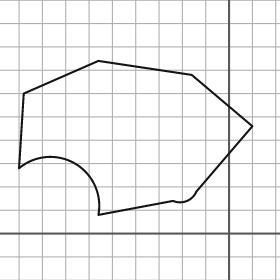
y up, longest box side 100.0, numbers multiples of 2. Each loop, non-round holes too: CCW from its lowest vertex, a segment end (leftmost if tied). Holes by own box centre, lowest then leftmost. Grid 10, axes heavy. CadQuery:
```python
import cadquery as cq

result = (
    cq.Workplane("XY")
    .moveTo(-56.0, 8.0)
    .lineTo(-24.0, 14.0)
    .threePointArc((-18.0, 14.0), (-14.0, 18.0))
    .lineTo(10.0, 46.0)
    .lineTo(-16.0, 68.0)
    .lineTo(-56.0, 74.0)
    .lineTo(-88.0, 60.0)
    .lineTo(-90.0, 28.0)
    .threePointArc((-66.0, 30.0), (-56.0, 8.0))
    .close()
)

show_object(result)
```